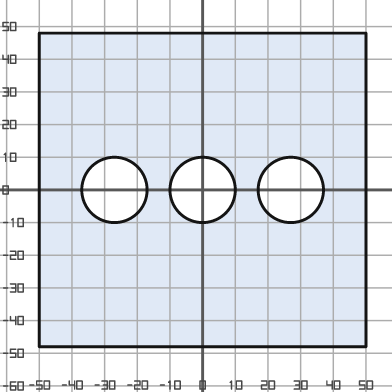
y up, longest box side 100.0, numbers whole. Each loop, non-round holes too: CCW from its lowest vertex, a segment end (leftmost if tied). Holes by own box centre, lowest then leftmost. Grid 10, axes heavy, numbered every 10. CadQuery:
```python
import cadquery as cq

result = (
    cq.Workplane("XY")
    .moveTo(-50.0, -48.0)
    .lineTo(50.0, -48.0)
    .lineTo(50.0, 48.0)
    .lineTo(-50.0, 48.0)
    .close()
    .moveTo(-27.0, 0.0)
    .circle(10.0)
    .moveTo(0.0, 0.0)
    .circle(10.0)
    .moveTo(27.0, 0.0)
    .circle(10.0)
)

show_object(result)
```